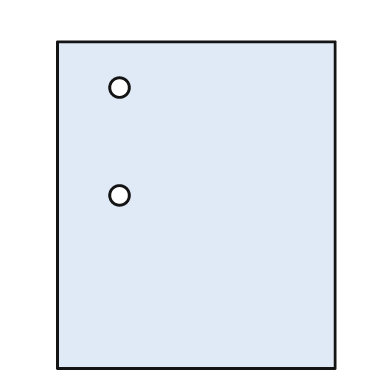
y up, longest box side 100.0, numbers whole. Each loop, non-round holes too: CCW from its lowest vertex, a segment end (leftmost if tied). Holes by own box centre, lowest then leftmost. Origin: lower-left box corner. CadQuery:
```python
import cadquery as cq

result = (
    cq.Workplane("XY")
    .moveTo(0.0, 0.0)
    .lineTo(85.0, 0.0)
    .lineTo(85.0, 100.0)
    .lineTo(0.0, 100.0)
    .close()
    .moveTo(19.0, 53.0)
    .circle(3.0)
    .moveTo(19.0, 86.0)
    .circle(3.0)
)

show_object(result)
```